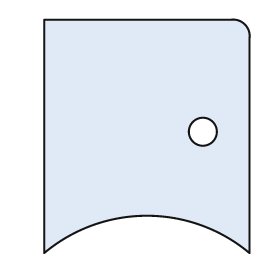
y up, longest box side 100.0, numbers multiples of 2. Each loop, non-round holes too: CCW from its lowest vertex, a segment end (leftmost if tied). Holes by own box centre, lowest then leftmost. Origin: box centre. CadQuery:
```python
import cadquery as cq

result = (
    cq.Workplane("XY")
    .moveTo(-44.0, -50.0)
    .threePointArc((0.0, -34.0), (44.0, -50.0))
    .lineTo(44.0, 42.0)
    .threePointArc((42.0, 48.0), (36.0, 50.0))
    .lineTo(-44.0, 50.0)
    .close()
    .moveTo(24.0, 2.0)
    .circle(6.0)
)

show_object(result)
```